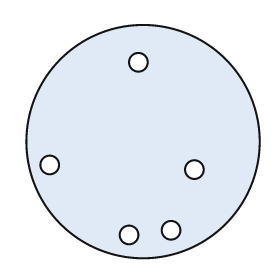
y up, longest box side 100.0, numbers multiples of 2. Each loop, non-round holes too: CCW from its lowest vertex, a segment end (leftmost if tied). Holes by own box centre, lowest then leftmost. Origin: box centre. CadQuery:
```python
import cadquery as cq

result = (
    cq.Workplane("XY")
    .moveTo(0.0, 0.0)
    .circle(50.0)
    .moveTo(-6.0, -40.0)
    .circle(4.0)
    .moveTo(12.0, -38.0)
    .circle(4.0)
    .moveTo(22.0, -12.0)
    .circle(4.0)
    .moveTo(-40.0, -10.0)
    .circle(4.0)
    .moveTo(-2.0, 34.0)
    .circle(4.0)
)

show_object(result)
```